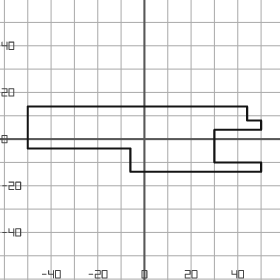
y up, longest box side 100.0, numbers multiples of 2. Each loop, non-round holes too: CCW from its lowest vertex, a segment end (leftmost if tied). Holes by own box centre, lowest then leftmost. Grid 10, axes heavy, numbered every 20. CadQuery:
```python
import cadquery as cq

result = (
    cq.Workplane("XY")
    .moveTo(-6.0, -14.0)
    .lineTo(50.0, -14.0)
    .lineTo(50.0, -10.0)
    .lineTo(30.0, -10.0)
    .lineTo(30.0, 4.0)
    .lineTo(50.0, 4.0)
    .lineTo(50.0, 8.0)
    .lineTo(44.0, 8.0)
    .lineTo(44.0, 14.0)
    .lineTo(-50.0, 14.0)
    .lineTo(-50.0, -4.0)
    .lineTo(-6.0, -4.0)
    .close()
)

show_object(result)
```